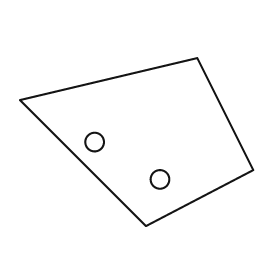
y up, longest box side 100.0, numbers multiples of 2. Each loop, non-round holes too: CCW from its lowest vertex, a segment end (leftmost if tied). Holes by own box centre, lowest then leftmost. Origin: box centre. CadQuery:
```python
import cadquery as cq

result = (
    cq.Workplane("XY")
    .moveTo(4.0, -36.0)
    .lineTo(50.0, -12.0)
    .lineTo(26.0, 36.0)
    .lineTo(-50.0, 18.0)
    .close()
    .moveTo(10.0, -16.0)
    .circle(4.0)
    .moveTo(-18.0, 0.0)
    .circle(4.0)
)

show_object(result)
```